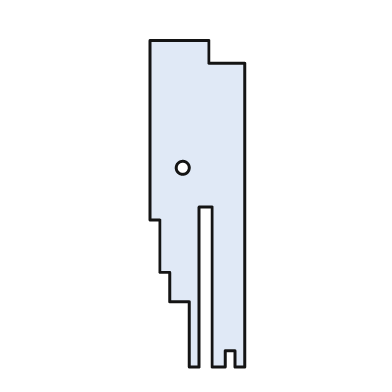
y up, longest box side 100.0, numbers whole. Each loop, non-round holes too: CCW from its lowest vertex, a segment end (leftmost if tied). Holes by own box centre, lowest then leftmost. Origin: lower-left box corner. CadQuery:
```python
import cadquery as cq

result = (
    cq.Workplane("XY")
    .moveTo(12.0, 0.0)
    .lineTo(15.0, 0.0)
    .lineTo(15.0, 49.0)
    .lineTo(19.0, 49.0)
    .lineTo(19.0, 0.0)
    .lineTo(23.0, 0.0)
    .lineTo(23.0, 5.0)
    .lineTo(26.0, 5.0)
    .lineTo(26.0, 0.0)
    .lineTo(29.0, 0.0)
    .lineTo(29.0, 93.0)
    .lineTo(18.0, 93.0)
    .lineTo(18.0, 100.0)
    .lineTo(0.0, 100.0)
    .lineTo(0.0, 45.0)
    .lineTo(3.0, 45.0)
    .lineTo(3.0, 29.0)
    .lineTo(6.0, 29.0)
    .lineTo(6.0, 20.0)
    .lineTo(12.0, 20.0)
    .close()
    .moveTo(10.0, 61.0)
    .circle(2.0)
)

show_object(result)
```